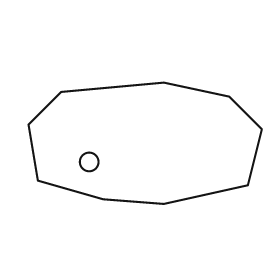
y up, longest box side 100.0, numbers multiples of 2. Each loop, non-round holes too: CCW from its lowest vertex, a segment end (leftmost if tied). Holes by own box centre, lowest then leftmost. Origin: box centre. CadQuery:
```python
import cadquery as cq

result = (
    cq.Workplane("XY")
    .moveTo(8.0, -26.0)
    .lineTo(44.0, -18.0)
    .lineTo(50.0, 6.0)
    .lineTo(36.0, 20.0)
    .lineTo(8.0, 26.0)
    .lineTo(-36.0, 22.0)
    .lineTo(-50.0, 8.0)
    .lineTo(-46.0, -16.0)
    .lineTo(-18.0, -24.0)
    .close()
    .moveTo(-24.0, -8.0)
    .circle(4.0)
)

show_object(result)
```